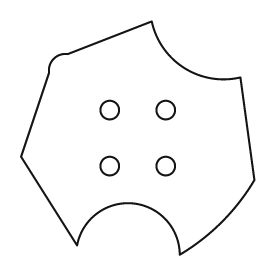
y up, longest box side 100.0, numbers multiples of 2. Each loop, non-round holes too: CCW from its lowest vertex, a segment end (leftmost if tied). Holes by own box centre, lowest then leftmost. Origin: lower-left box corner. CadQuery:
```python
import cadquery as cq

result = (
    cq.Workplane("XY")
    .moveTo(68.0, 0.0)
    .threePointArc((86.0, 14.0), (100.0, 32.0))
    .lineTo(94.0, 76.0)
    .threePointArc((70.0, 80.0), (56.0, 100.0))
    .lineTo(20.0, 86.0)
    .threePointArc((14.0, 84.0), (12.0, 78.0))
    .lineTo(0.0, 42.0)
    .lineTo(24.0, 4.0)
    .threePointArc((48.0, 22.0), (68.0, 0.0))
    .close()
    .moveTo(38.0, 38.0)
    .circle(4.0)
    .moveTo(62.0, 38.0)
    .circle(4.0)
    .moveTo(38.0, 62.0)
    .circle(4.0)
    .moveTo(62.0, 62.0)
    .circle(4.0)
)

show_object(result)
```